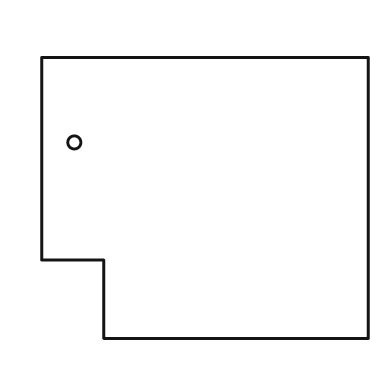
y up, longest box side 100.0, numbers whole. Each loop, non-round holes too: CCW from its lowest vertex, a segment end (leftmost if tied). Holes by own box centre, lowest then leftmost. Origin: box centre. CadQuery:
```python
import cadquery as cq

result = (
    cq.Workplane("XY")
    .moveTo(-31.0, -43.0)
    .lineTo(50.0, -43.0)
    .lineTo(50.0, 43.0)
    .lineTo(-50.0, 43.0)
    .lineTo(-50.0, -19.0)
    .lineTo(-31.0, -19.0)
    .close()
    .moveTo(-40.0, 17.0)
    .circle(2.0)
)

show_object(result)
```